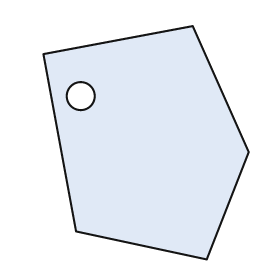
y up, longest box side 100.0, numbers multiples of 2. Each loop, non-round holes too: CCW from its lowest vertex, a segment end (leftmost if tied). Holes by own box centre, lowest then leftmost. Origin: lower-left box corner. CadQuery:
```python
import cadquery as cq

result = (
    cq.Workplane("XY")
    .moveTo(70.0, 0.0)
    .lineTo(88.0, 46.0)
    .lineTo(64.0, 100.0)
    .lineTo(0.0, 88.0)
    .lineTo(14.0, 12.0)
    .close()
    .moveTo(16.0, 70.0)
    .circle(6.0)
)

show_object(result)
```